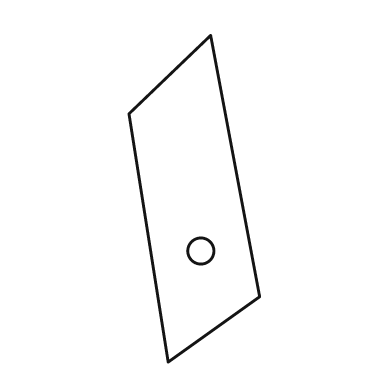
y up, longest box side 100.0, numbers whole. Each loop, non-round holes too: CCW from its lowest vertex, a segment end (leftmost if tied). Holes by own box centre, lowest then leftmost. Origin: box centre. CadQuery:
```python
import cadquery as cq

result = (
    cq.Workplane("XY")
    .moveTo(-8.0, -50.0)
    .lineTo(20.0, -30.0)
    .lineTo(5.0, 50.0)
    .lineTo(-20.0, 26.0)
    .close()
    .moveTo(2.0, -16.0)
    .circle(4.0)
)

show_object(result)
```